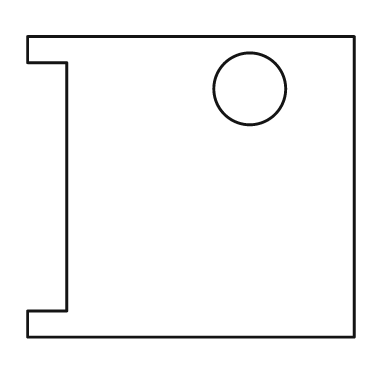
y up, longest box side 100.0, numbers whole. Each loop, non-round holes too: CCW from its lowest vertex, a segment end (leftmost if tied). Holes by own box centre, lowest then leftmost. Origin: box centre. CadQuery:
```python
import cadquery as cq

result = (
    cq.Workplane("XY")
    .moveTo(-50.0, -46.0)
    .lineTo(50.0, -46.0)
    .lineTo(50.0, 46.0)
    .lineTo(-50.0, 46.0)
    .lineTo(-50.0, 38.0)
    .lineTo(-38.0, 38.0)
    .lineTo(-38.0, -38.0)
    .lineTo(-50.0, -38.0)
    .close()
    .moveTo(18.0, 30.0)
    .circle(11.0)
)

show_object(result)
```